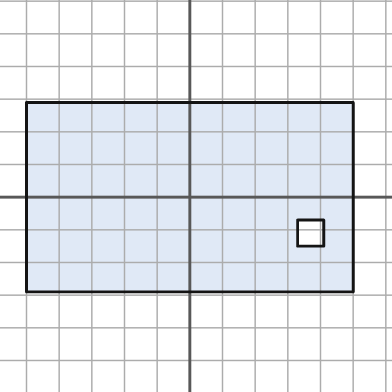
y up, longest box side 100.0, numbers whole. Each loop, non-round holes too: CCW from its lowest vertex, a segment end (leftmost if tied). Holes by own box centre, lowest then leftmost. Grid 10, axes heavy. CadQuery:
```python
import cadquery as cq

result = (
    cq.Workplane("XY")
    .moveTo(-50.0, -29.0)
    .lineTo(50.0, -29.0)
    .lineTo(50.0, 29.0)
    .lineTo(-50.0, 29.0)
    .close()
    .moveTo(33.0, -15.0)
    .lineTo(41.0, -15.0)
    .lineTo(41.0, -7.0)
    .lineTo(33.0, -7.0)
    .close()
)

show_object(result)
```